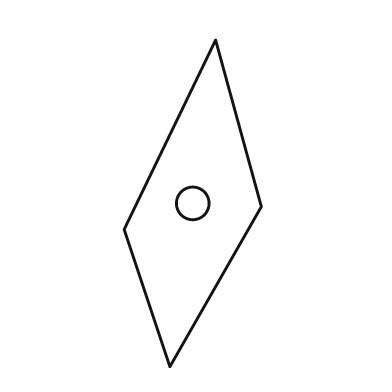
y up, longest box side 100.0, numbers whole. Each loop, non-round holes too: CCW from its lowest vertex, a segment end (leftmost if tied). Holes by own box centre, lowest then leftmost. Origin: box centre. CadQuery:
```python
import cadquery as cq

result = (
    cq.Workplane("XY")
    .moveTo(-7.0, -50.0)
    .lineTo(21.0, -1.0)
    .lineTo(7.0, 50.0)
    .lineTo(-21.0, -8.0)
    .close()
    .moveTo(0.0, 0.0)
    .circle(5.0)
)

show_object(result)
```